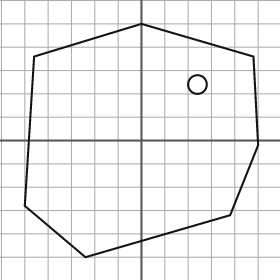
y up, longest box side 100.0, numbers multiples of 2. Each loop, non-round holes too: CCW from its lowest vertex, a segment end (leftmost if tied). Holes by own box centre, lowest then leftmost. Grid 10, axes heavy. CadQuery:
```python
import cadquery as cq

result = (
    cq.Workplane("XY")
    .moveTo(-24.0, -50.0)
    .lineTo(38.0, -32.0)
    .lineTo(50.0, -2.0)
    .lineTo(48.0, 36.0)
    .lineTo(0.0, 50.0)
    .lineTo(-46.0, 36.0)
    .lineTo(-50.0, -28.0)
    .close()
    .moveTo(24.0, 24.0)
    .circle(4.0)
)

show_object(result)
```